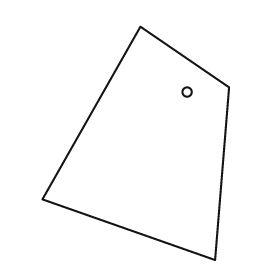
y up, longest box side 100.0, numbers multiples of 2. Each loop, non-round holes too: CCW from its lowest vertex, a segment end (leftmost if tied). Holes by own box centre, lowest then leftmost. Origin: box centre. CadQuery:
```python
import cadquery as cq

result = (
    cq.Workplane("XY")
    .moveTo(34.0, -50.0)
    .lineTo(40.0, 24.0)
    .lineTo(2.0, 50.0)
    .lineTo(-40.0, -24.0)
    .close()
    .moveTo(22.0, 22.0)
    .circle(2.0)
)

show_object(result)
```